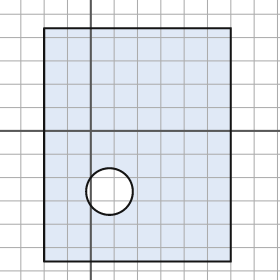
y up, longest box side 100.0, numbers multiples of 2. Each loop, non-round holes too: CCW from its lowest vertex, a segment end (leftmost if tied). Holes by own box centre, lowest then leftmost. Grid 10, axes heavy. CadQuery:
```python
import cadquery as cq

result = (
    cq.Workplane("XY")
    .moveTo(-20.0, -56.0)
    .lineTo(60.0, -56.0)
    .lineTo(60.0, 44.0)
    .lineTo(-20.0, 44.0)
    .close()
    .moveTo(8.0, -26.0)
    .circle(10.0)
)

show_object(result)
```